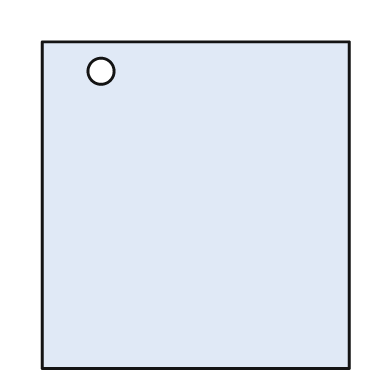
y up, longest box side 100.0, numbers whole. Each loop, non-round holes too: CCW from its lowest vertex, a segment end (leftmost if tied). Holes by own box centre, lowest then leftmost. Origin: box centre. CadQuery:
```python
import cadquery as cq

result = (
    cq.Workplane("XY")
    .moveTo(-47.0, -50.0)
    .lineTo(47.0, -50.0)
    .lineTo(47.0, 50.0)
    .lineTo(-47.0, 50.0)
    .close()
    .moveTo(-29.0, 41.0)
    .circle(4.0)
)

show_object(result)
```